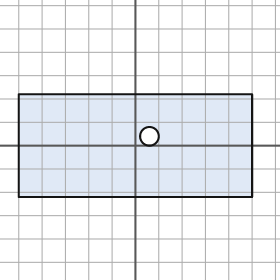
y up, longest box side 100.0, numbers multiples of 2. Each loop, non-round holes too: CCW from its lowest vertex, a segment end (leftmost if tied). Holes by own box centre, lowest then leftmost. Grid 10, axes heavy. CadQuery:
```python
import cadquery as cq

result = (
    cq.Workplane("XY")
    .moveTo(-50.0, -22.0)
    .lineTo(50.0, -22.0)
    .lineTo(50.0, 22.0)
    .lineTo(-50.0, 22.0)
    .close()
    .moveTo(6.0, 4.0)
    .circle(4.0)
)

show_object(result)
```